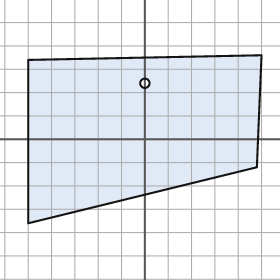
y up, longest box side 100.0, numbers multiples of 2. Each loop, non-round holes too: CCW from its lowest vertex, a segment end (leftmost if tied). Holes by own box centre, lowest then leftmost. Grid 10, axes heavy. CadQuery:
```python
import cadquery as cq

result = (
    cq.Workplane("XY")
    .moveTo(-50.0, -36.0)
    .lineTo(48.0, -12.0)
    .lineTo(50.0, 36.0)
    .lineTo(-50.0, 34.0)
    .close()
    .moveTo(0.0, 24.0)
    .circle(2.0)
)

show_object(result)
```